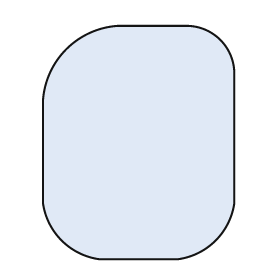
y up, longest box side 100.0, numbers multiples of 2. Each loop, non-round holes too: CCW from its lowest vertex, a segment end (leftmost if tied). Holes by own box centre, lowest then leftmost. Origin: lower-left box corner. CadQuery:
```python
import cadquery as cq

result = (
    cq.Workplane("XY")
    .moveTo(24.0, 0.0)
    .lineTo(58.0, 0.0)
    .threePointArc((74.0, 8.0), (82.0, 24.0))
    .lineTo(82.0, 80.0)
    .threePointArc((76.0, 94.0), (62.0, 100.0))
    .lineTo(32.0, 100.0)
    .threePointArc((10.0, 90.0), (0.0, 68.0))
    .lineTo(0.0, 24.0)
    .threePointArc((8.0, 8.0), (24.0, 0.0))
    .close()
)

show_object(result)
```